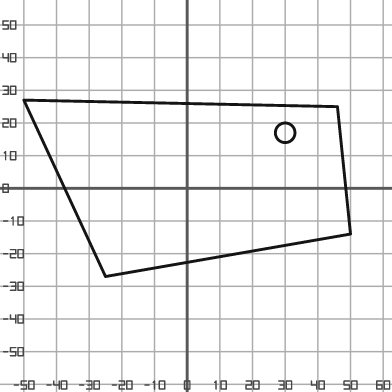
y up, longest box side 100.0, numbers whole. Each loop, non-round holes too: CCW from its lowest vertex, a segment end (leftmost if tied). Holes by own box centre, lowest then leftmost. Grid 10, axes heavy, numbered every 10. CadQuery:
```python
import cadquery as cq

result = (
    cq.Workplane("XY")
    .moveTo(-25.0, -27.0)
    .lineTo(50.0, -14.0)
    .lineTo(46.0, 25.0)
    .lineTo(-50.0, 27.0)
    .close()
    .moveTo(30.0, 17.0)
    .circle(3.0)
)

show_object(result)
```